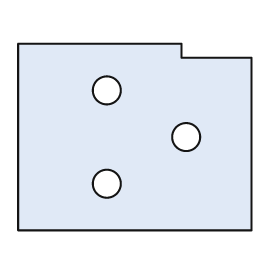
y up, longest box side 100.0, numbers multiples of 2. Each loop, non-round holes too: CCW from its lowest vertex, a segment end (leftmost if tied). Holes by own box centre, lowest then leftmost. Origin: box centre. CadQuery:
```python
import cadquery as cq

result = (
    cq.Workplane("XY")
    .moveTo(-50.0, -40.0)
    .lineTo(50.0, -40.0)
    .lineTo(50.0, 34.0)
    .lineTo(20.0, 34.0)
    .lineTo(20.0, 40.0)
    .lineTo(-50.0, 40.0)
    .close()
    .moveTo(-12.0, -20.0)
    .circle(6.0)
    .moveTo(22.0, 0.0)
    .circle(6.0)
    .moveTo(-12.0, 20.0)
    .circle(6.0)
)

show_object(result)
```